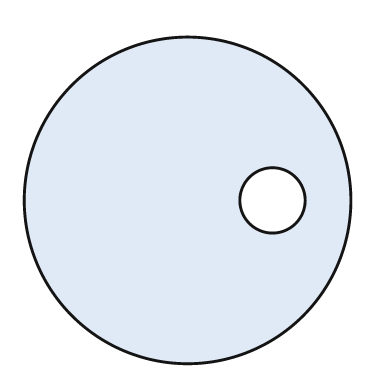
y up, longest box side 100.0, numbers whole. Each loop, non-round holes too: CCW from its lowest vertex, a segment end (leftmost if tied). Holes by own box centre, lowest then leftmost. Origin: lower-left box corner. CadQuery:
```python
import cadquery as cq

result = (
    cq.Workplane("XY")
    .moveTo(50.0, 50.0)
    .circle(50.0)
    .moveTo(76.0, 50.0)
    .circle(10.0)
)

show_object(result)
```